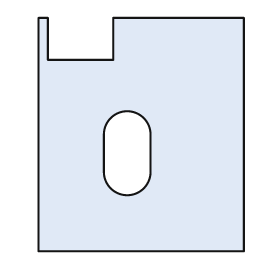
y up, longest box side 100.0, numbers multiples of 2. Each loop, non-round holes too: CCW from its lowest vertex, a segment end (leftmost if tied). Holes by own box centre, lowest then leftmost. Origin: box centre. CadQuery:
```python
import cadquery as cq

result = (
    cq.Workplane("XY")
    .moveTo(-44.0, -50.0)
    .lineTo(44.0, -50.0)
    .lineTo(44.0, 50.0)
    .lineTo(-12.0, 50.0)
    .lineTo(-12.0, 32.0)
    .lineTo(-40.0, 32.0)
    .lineTo(-40.0, 50.0)
    .lineTo(-44.0, 50.0)
    .close()
    .moveTo(-16.0, -16.0)
    .threePointArc((-6.0, -26.0), (4.0, -16.0))
    .lineTo(4.0, 0.0)
    .threePointArc((-6.0, 10.0), (-16.0, 0.0))
    .close()
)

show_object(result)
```